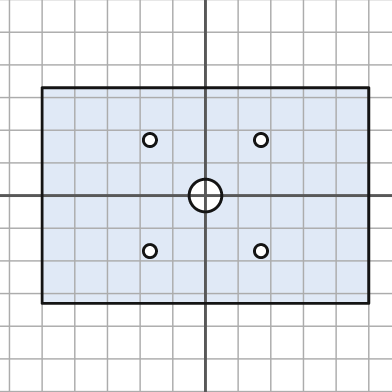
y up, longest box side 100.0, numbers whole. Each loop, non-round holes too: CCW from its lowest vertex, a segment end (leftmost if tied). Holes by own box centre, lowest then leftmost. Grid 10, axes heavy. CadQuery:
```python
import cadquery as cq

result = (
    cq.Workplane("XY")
    .moveTo(-50.0, -33.0)
    .lineTo(50.0, -33.0)
    .lineTo(50.0, 33.0)
    .lineTo(-50.0, 33.0)
    .close()
    .moveTo(-17.0, -17.0)
    .circle(2.0)
    .moveTo(17.0, -17.0)
    .circle(2.0)
    .moveTo(0.0, 0.0)
    .circle(5.0)
    .moveTo(-17.0, 17.0)
    .circle(2.0)
    .moveTo(17.0, 17.0)
    .circle(2.0)
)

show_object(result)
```